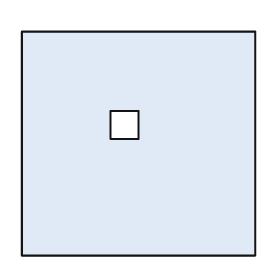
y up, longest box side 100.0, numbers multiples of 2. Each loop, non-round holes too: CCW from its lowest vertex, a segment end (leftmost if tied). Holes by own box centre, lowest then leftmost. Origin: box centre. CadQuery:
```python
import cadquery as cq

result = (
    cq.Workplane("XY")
    .moveTo(-50.0, -48.0)
    .lineTo(50.0, -48.0)
    .lineTo(50.0, 48.0)
    .lineTo(-50.0, 48.0)
    .close()
    .moveTo(-12.0, 2.0)
    .lineTo(0.0, 2.0)
    .lineTo(0.0, 14.0)
    .lineTo(-12.0, 14.0)
    .close()
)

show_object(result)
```